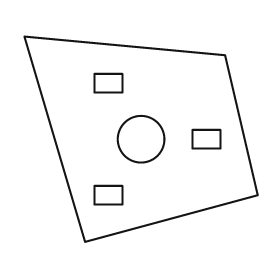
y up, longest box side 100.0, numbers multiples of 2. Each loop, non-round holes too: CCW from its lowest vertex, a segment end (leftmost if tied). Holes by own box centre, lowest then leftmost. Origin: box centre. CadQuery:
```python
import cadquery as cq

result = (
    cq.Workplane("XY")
    .moveTo(-24.0, -44.0)
    .lineTo(50.0, -24.0)
    .lineTo(36.0, 36.0)
    .lineTo(-50.0, 44.0)
    .close()
    .moveTo(-20.0, -28.0)
    .lineTo(-8.0, -28.0)
    .lineTo(-8.0, -20.0)
    .lineTo(-20.0, -20.0)
    .close()
    .moveTo(0.0, 0.0)
    .circle(10.0)
    .moveTo(22.0, -4.0)
    .lineTo(34.0, -4.0)
    .lineTo(34.0, 4.0)
    .lineTo(22.0, 4.0)
    .close()
    .moveTo(-20.0, 20.0)
    .lineTo(-8.0, 20.0)
    .lineTo(-8.0, 28.0)
    .lineTo(-20.0, 28.0)
    .close()
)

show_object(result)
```